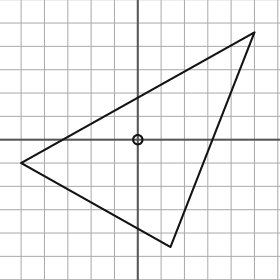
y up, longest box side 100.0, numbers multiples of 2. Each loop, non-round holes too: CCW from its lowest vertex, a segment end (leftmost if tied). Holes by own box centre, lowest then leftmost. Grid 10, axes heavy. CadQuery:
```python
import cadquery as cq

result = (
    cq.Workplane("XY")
    .moveTo(14.0, -46.0)
    .lineTo(50.0, 46.0)
    .lineTo(-50.0, -10.0)
    .close()
    .moveTo(0.0, 0.0)
    .circle(2.0)
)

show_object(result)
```